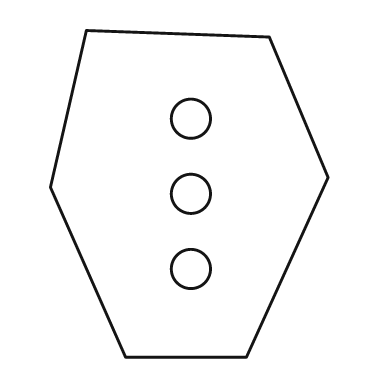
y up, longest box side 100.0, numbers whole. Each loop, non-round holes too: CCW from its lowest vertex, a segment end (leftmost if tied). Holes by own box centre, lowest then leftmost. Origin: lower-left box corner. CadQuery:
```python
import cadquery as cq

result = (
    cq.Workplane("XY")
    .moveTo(23.0, 0.0)
    .lineTo(60.0, 0.0)
    .lineTo(85.0, 55.0)
    .lineTo(67.0, 98.0)
    .lineTo(11.0, 100.0)
    .lineTo(0.0, 52.0)
    .close()
    .moveTo(43.0, 27.0)
    .circle(6.0)
    .moveTo(43.0, 50.0)
    .circle(6.0)
    .moveTo(43.0, 73.0)
    .circle(6.0)
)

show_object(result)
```